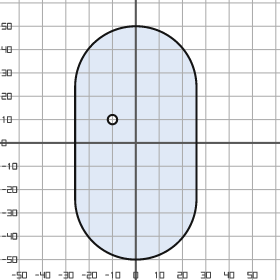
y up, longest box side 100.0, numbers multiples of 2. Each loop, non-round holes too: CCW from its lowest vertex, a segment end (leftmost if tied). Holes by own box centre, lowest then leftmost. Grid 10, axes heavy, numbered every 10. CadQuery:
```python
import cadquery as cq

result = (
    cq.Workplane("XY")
    .moveTo(-26.0, -24.0)
    .threePointArc((0.0, -50.0), (26.0, -24.0))
    .lineTo(26.0, 24.0)
    .threePointArc((0.0, 50.0), (-26.0, 24.0))
    .close()
    .moveTo(-10.0, 10.0)
    .circle(2.0)
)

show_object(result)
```